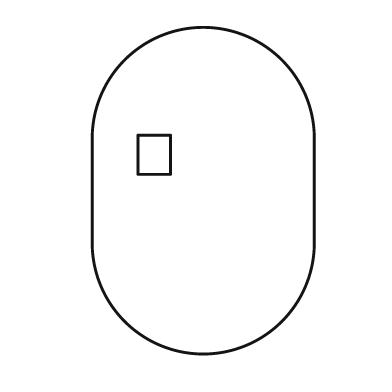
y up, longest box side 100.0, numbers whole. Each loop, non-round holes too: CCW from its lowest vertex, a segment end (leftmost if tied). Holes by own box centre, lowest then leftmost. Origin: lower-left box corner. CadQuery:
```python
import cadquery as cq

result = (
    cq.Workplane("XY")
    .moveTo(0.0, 34.0)
    .threePointArc((34.0, 0.0), (68.0, 34.0))
    .lineTo(68.0, 66.0)
    .threePointArc((34.0, 100.0), (0.0, 66.0))
    .close()
    .moveTo(14.0, 55.0)
    .lineTo(24.0, 55.0)
    .lineTo(24.0, 67.0)
    .lineTo(14.0, 67.0)
    .close()
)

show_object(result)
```